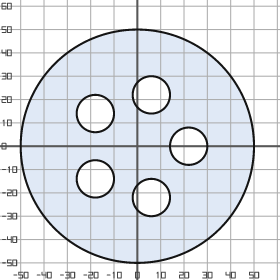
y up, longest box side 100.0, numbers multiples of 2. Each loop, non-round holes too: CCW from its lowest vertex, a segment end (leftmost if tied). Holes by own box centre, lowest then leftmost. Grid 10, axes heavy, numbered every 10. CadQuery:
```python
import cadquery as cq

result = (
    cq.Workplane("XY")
    .moveTo(0.0, 0.0)
    .circle(50.0)
    .moveTo(6.0, -22.0)
    .circle(8.0)
    .moveTo(-18.0, -14.0)
    .circle(8.0)
    .moveTo(22.0, 0.0)
    .circle(8.0)
    .moveTo(-18.0, 14.0)
    .circle(8.0)
    .moveTo(6.0, 22.0)
    .circle(8.0)
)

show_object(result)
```